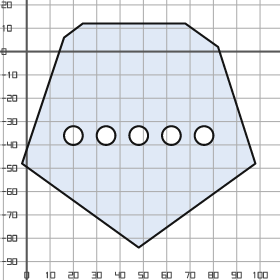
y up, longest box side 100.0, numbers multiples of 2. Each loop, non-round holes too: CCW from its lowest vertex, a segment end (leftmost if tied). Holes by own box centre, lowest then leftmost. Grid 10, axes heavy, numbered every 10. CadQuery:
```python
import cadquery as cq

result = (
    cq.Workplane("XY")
    .moveTo(48.0, -84.0)
    .lineTo(98.0, -48.0)
    .lineTo(82.0, 2.0)
    .lineTo(68.0, 12.0)
    .lineTo(24.0, 12.0)
    .lineTo(16.0, 6.0)
    .lineTo(-2.0, -48.0)
    .close()
    .moveTo(20.0, -36.0)
    .circle(4.0)
    .moveTo(34.0, -36.0)
    .circle(4.0)
    .moveTo(48.0, -36.0)
    .circle(4.0)
    .moveTo(62.0, -36.0)
    .circle(4.0)
    .moveTo(76.0, -36.0)
    .circle(4.0)
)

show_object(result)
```